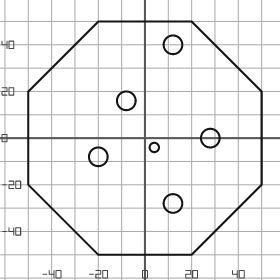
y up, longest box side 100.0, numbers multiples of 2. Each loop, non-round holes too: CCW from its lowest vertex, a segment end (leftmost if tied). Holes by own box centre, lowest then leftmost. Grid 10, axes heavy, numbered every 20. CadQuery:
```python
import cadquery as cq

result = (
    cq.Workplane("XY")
    .moveTo(-20.0, -50.0)
    .lineTo(20.0, -50.0)
    .lineTo(50.0, -20.0)
    .lineTo(50.0, 20.0)
    .lineTo(20.0, 50.0)
    .lineTo(-20.0, 50.0)
    .lineTo(-50.0, 20.0)
    .lineTo(-50.0, -20.0)
    .close()
    .moveTo(12.0, -28.0)
    .circle(4.0)
    .moveTo(-20.0, -8.0)
    .circle(4.0)
    .moveTo(4.0, -4.0)
    .circle(2.0)
    .moveTo(28.0, 0.0)
    .circle(4.0)
    .moveTo(-8.0, 16.0)
    .circle(4.0)
    .moveTo(12.0, 40.0)
    .circle(4.0)
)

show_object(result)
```